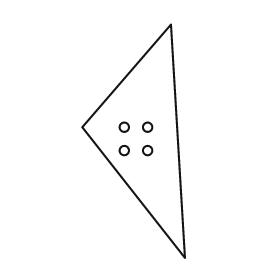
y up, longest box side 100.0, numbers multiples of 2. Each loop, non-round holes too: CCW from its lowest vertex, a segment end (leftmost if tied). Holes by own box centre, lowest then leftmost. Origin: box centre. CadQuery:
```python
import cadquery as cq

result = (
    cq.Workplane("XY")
    .moveTo(22.0, -50.0)
    .lineTo(16.0, 50.0)
    .lineTo(-22.0, 6.0)
    .close()
    .moveTo(-4.0, -4.0)
    .circle(2.0)
    .moveTo(6.0, -4.0)
    .circle(2.0)
    .moveTo(-4.0, 6.0)
    .circle(2.0)
    .moveTo(6.0, 6.0)
    .circle(2.0)
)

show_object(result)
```